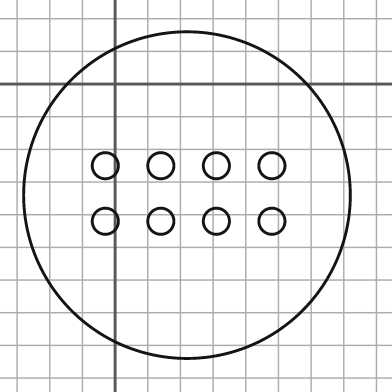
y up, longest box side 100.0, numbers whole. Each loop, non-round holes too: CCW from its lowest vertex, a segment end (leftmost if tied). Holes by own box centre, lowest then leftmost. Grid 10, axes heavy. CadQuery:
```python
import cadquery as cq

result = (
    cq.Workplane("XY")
    .moveTo(22.0, -34.0)
    .circle(50.0)
    .moveTo(-3.0, -42.0)
    .circle(4.0)
    .moveTo(14.0, -42.0)
    .circle(4.0)
    .moveTo(31.0, -42.0)
    .circle(4.0)
    .moveTo(48.0, -42.0)
    .circle(4.0)
    .moveTo(-3.0, -25.0)
    .circle(4.0)
    .moveTo(14.0, -25.0)
    .circle(4.0)
    .moveTo(31.0, -25.0)
    .circle(4.0)
    .moveTo(48.0, -25.0)
    .circle(4.0)
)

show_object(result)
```